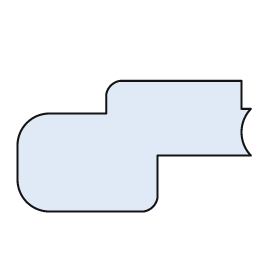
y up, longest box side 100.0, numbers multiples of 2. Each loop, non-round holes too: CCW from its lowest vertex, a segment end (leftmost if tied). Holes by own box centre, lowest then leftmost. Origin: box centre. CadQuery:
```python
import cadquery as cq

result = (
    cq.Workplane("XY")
    .moveTo(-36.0, -28.0)
    .lineTo(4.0, -28.0)
    .threePointArc((8.0, -26.0), (10.0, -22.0))
    .lineTo(10.0, -4.0)
    .lineTo(50.0, -4.0)
    .threePointArc((46.0, 6.0), (50.0, 16.0))
    .lineTo(46.0, 16.0)
    .lineTo(46.0, 28.0)
    .lineTo(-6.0, 28.0)
    .threePointArc((-10.0, 26.0), (-12.0, 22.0))
    .lineTo(-12.0, 14.0)
    .lineTo(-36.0, 14.0)
    .threePointArc((-46.0, 10.0), (-50.0, 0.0))
    .lineTo(-50.0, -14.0)
    .threePointArc((-46.0, -24.0), (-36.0, -28.0))
    .close()
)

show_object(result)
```